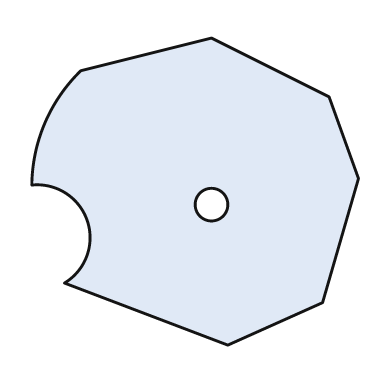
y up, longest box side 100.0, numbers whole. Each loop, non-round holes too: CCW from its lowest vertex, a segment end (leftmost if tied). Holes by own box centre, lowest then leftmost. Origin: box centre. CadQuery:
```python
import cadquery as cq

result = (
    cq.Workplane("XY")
    .moveTo(10.0, -47.0)
    .lineTo(39.0, -34.0)
    .lineTo(50.0, 4.0)
    .lineTo(41.0, 29.0)
    .lineTo(5.0, 47.0)
    .lineTo(-35.0, 37.0)
    .threePointArc((-46.0, 21.0), (-50.0, 2.0))
    .threePointArc((-33.0, -9.0), (-40.0, -28.0))
    .close()
    .moveTo(5.0, -4.0)
    .circle(5.0)
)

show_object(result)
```